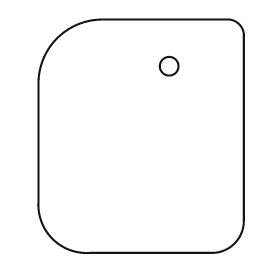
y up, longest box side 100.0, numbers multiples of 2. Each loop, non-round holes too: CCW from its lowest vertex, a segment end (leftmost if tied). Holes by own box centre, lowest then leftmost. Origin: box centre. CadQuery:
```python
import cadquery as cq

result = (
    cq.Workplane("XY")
    .moveTo(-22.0, -50.0)
    .lineTo(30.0, -50.0)
    .threePointArc((40.0, -46.0), (44.0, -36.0))
    .lineTo(44.0, 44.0)
    .threePointArc((42.0, 48.0), (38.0, 50.0))
    .lineTo(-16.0, 50.0)
    .threePointArc((-36.0, 42.0), (-44.0, 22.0))
    .lineTo(-44.0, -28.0)
    .threePointArc((-38.0, -44.0), (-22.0, -50.0))
    .close()
    .moveTo(12.0, 30.0)
    .circle(4.0)
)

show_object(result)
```